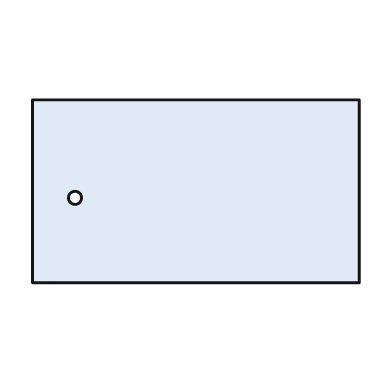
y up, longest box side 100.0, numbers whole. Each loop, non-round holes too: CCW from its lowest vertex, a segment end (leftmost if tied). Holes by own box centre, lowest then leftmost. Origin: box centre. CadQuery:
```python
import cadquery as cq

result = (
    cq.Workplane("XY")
    .moveTo(-50.0, -28.0)
    .lineTo(50.0, -28.0)
    .lineTo(50.0, 28.0)
    .lineTo(-50.0, 28.0)
    .close()
    .moveTo(-37.0, -2.0)
    .circle(2.0)
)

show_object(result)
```